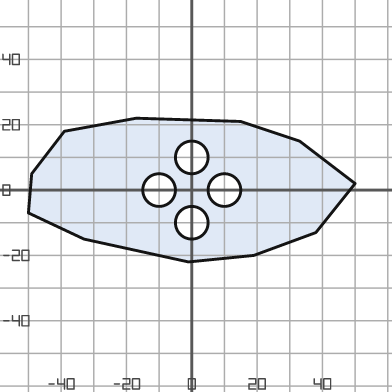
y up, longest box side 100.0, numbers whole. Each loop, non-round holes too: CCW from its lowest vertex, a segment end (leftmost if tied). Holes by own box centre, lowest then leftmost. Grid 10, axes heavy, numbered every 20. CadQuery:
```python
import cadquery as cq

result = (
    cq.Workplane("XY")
    .moveTo(-1.0, -22.0)
    .lineTo(19.0, -20.0)
    .lineTo(38.0, -13.0)
    .lineTo(50.0, 2.0)
    .lineTo(33.0, 15.0)
    .lineTo(15.0, 21.0)
    .lineTo(-17.0, 22.0)
    .lineTo(-39.0, 18.0)
    .lineTo(-49.0, 5.0)
    .lineTo(-50.0, -7.0)
    .lineTo(-33.0, -15.0)
    .close()
    .moveTo(0.0, -10.0)
    .circle(5.0)
    .moveTo(-10.0, 0.0)
    .circle(5.0)
    .moveTo(10.0, 0.0)
    .circle(5.0)
    .moveTo(0.0, 10.0)
    .circle(5.0)
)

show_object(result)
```